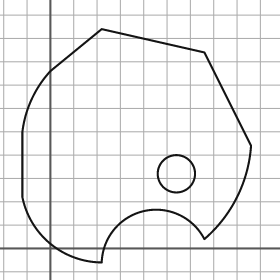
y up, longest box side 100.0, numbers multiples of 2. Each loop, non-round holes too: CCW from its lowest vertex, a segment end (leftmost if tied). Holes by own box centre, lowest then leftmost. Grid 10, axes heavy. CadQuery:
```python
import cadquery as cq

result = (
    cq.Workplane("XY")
    .moveTo(22.0, -6.0)
    .threePointArc((40.0, 16.0), (66.0, 4.0))
    .threePointArc((80.0, 22.0), (86.0, 44.0))
    .lineTo(66.0, 84.0)
    .lineTo(22.0, 94.0)
    .lineTo(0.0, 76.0)
    .threePointArc((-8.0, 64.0), (-12.0, 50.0))
    .lineTo(-12.0, 22.0)
    .threePointArc((0.0, 2.0), (22.0, -6.0))
    .close()
    .moveTo(54.0, 32.0)
    .circle(8.0)
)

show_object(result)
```